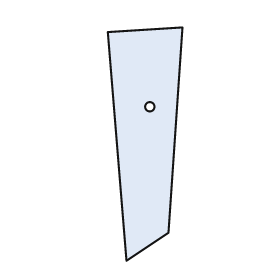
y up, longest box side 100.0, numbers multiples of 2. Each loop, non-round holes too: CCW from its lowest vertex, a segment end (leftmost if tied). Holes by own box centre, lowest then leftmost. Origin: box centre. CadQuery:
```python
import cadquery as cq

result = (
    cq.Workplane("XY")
    .moveTo(-8.0, -50.0)
    .lineTo(10.0, -38.0)
    .lineTo(16.0, 50.0)
    .lineTo(-16.0, 48.0)
    .close()
    .moveTo(2.0, 16.0)
    .circle(2.0)
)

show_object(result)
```